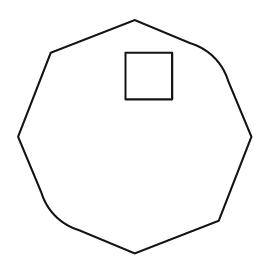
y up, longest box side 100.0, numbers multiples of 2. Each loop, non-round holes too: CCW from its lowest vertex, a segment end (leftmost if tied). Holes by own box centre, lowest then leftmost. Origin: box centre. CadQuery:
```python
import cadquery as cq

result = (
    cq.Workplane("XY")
    .moveTo(0.0, -50.0)
    .lineTo(36.0, -36.0)
    .lineTo(50.0, 0.0)
    .lineTo(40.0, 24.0)
    .threePointArc((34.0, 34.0), (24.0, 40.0))
    .lineTo(0.0, 50.0)
    .lineTo(-36.0, 36.0)
    .lineTo(-50.0, 0.0)
    .lineTo(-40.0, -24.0)
    .threePointArc((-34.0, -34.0), (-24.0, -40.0))
    .close()
    .moveTo(-4.0, 16.0)
    .lineTo(16.0, 16.0)
    .lineTo(16.0, 36.0)
    .lineTo(-4.0, 36.0)
    .close()
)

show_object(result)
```